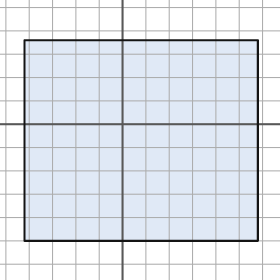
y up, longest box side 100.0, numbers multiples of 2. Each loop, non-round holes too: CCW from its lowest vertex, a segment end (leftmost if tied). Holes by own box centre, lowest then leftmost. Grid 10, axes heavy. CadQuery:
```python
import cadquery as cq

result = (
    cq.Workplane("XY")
    .moveTo(-42.0, -50.0)
    .lineTo(58.0, -50.0)
    .lineTo(58.0, 36.0)
    .lineTo(-42.0, 36.0)
    .close()
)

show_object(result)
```